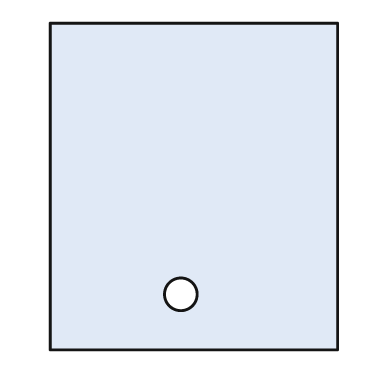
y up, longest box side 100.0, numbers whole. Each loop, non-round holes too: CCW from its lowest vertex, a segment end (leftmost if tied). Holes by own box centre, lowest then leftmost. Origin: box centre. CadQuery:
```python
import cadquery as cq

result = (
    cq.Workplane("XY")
    .moveTo(-44.0, -50.0)
    .lineTo(44.0, -50.0)
    .lineTo(44.0, 50.0)
    .lineTo(-44.0, 50.0)
    .close()
    .moveTo(-4.0, -33.0)
    .circle(5.0)
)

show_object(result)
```